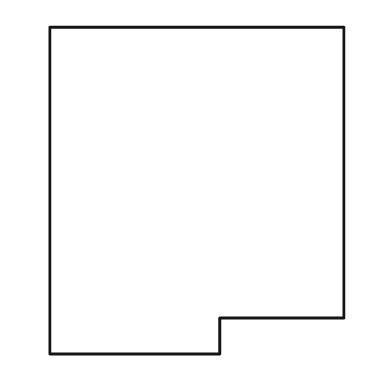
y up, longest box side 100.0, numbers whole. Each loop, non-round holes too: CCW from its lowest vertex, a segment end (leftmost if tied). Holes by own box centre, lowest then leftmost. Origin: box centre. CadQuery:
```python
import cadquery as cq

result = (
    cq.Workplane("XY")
    .moveTo(-45.0, -50.0)
    .lineTo(7.0, -50.0)
    .lineTo(7.0, -39.0)
    .lineTo(45.0, -39.0)
    .lineTo(45.0, 50.0)
    .lineTo(-45.0, 50.0)
    .close()
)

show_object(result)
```